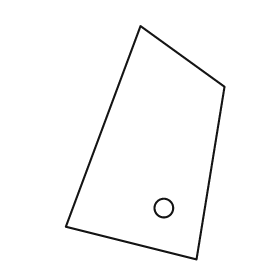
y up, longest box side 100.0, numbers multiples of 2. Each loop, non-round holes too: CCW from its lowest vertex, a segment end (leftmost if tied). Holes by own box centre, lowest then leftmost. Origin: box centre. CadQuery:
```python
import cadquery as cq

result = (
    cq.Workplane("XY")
    .moveTo(22.0, -50.0)
    .lineTo(34.0, 24.0)
    .lineTo(-2.0, 50.0)
    .lineTo(-34.0, -36.0)
    .close()
    .moveTo(8.0, -28.0)
    .circle(4.0)
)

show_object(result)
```